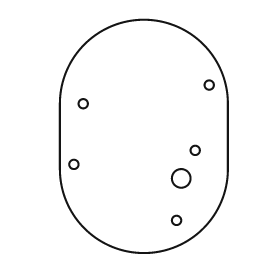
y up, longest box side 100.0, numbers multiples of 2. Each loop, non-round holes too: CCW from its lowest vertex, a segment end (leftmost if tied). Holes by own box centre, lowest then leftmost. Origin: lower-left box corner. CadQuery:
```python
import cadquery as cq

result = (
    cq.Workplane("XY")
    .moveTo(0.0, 36.0)
    .threePointArc((36.0, 0.0), (72.0, 36.0))
    .lineTo(72.0, 64.0)
    .threePointArc((36.0, 100.0), (0.0, 64.0))
    .close()
    .moveTo(50.0, 14.0)
    .circle(2.0)
    .moveTo(52.0, 32.0)
    .circle(4.0)
    .moveTo(6.0, 38.0)
    .circle(2.0)
    .moveTo(58.0, 44.0)
    .circle(2.0)
    .moveTo(10.0, 64.0)
    .circle(2.0)
    .moveTo(64.0, 72.0)
    .circle(2.0)
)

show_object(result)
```